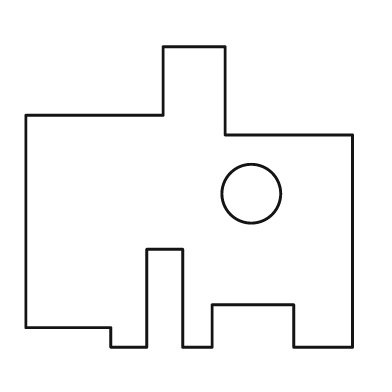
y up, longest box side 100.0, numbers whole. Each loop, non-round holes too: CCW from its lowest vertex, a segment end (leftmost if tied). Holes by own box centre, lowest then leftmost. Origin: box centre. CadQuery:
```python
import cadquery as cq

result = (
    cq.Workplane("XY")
    .moveTo(-24.0, -46.0)
    .lineTo(-13.0, -46.0)
    .lineTo(-13.0, -16.0)
    .lineTo(-2.0, -16.0)
    .lineTo(-2.0, -46.0)
    .lineTo(7.0, -46.0)
    .lineTo(7.0, -33.0)
    .lineTo(32.0, -33.0)
    .lineTo(32.0, -46.0)
    .lineTo(50.0, -46.0)
    .lineTo(50.0, 19.0)
    .lineTo(11.0, 19.0)
    .lineTo(11.0, 46.0)
    .lineTo(-8.0, 46.0)
    .lineTo(-8.0, 25.0)
    .lineTo(-50.0, 25.0)
    .lineTo(-50.0, -40.0)
    .lineTo(-24.0, -40.0)
    .close()
    .moveTo(19.0, 1.0)
    .circle(9.0)
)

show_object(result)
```